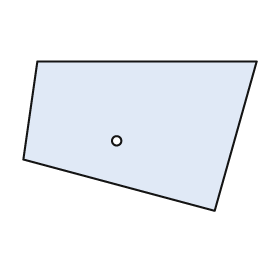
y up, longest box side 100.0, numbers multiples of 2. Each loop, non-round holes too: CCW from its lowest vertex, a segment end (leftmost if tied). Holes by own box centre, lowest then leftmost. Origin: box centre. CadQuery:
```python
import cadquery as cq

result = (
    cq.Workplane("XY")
    .moveTo(32.0, -32.0)
    .lineTo(50.0, 32.0)
    .lineTo(-44.0, 32.0)
    .lineTo(-50.0, -10.0)
    .close()
    .moveTo(-10.0, -2.0)
    .circle(2.0)
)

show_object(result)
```